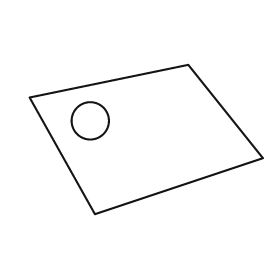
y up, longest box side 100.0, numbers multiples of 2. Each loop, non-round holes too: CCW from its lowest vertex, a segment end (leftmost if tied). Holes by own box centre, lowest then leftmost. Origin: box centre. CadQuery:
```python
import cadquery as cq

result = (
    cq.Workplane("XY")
    .moveTo(-22.0, -32.0)
    .lineTo(50.0, -8.0)
    .lineTo(18.0, 32.0)
    .lineTo(-50.0, 18.0)
    .close()
    .moveTo(-24.0, 8.0)
    .circle(8.0)
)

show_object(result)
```